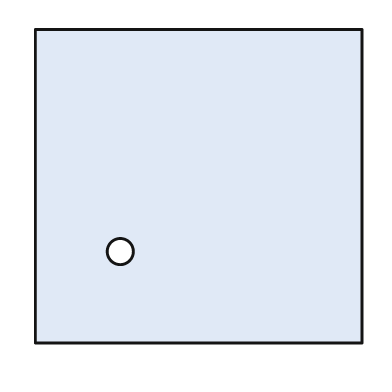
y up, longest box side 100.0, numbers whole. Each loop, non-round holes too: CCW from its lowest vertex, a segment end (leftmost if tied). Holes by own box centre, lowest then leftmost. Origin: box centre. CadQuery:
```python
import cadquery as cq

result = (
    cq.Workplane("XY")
    .moveTo(-50.0, -48.0)
    .lineTo(50.0, -48.0)
    .lineTo(50.0, 48.0)
    .lineTo(-50.0, 48.0)
    .close()
    .moveTo(-24.0, -20.0)
    .circle(4.0)
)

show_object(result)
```